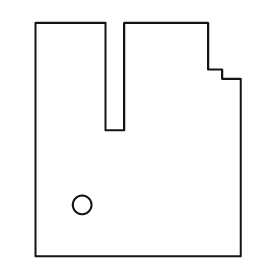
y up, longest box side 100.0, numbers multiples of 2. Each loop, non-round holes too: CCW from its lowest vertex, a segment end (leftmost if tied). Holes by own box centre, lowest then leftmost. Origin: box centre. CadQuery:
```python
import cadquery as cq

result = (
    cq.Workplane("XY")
    .moveTo(-44.0, -50.0)
    .lineTo(44.0, -50.0)
    .lineTo(44.0, 26.0)
    .lineTo(36.0, 26.0)
    .lineTo(36.0, 30.0)
    .lineTo(30.0, 30.0)
    .lineTo(30.0, 50.0)
    .lineTo(-6.0, 50.0)
    .lineTo(-6.0, 4.0)
    .lineTo(-14.0, 4.0)
    .lineTo(-14.0, 50.0)
    .lineTo(-44.0, 50.0)
    .close()
    .moveTo(-24.0, -28.0)
    .circle(4.0)
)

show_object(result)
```